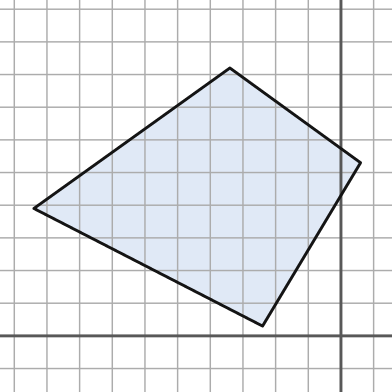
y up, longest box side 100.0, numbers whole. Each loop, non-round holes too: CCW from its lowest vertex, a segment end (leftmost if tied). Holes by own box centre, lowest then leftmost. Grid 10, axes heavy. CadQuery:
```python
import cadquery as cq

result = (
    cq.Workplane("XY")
    .moveTo(-24.0, 3.0)
    .lineTo(6.0, 53.0)
    .lineTo(-34.0, 82.0)
    .lineTo(-94.0, 39.0)
    .close()
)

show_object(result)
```